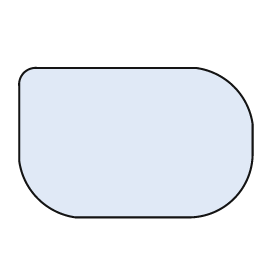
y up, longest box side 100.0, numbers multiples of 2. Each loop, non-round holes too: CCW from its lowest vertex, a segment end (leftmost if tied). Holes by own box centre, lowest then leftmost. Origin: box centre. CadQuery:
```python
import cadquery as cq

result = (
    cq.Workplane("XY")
    .moveTo(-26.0, -32.0)
    .lineTo(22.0, -32.0)
    .threePointArc((42.0, -24.0), (50.0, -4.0))
    .lineTo(50.0, 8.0)
    .threePointArc((42.0, 24.0), (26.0, 32.0))
    .lineTo(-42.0, 32.0)
    .threePointArc((-48.0, 30.0), (-50.0, 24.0))
    .lineTo(-50.0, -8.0)
    .threePointArc((-42.0, -24.0), (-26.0, -32.0))
    .close()
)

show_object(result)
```